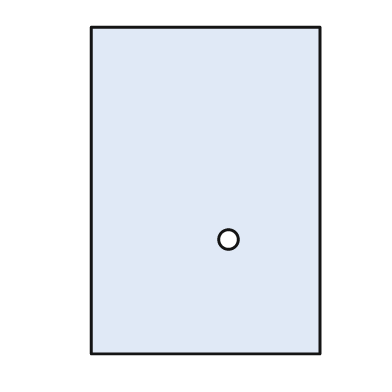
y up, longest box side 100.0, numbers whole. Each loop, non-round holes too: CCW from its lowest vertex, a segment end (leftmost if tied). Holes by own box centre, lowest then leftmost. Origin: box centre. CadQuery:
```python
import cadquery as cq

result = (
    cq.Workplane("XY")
    .moveTo(-35.0, -50.0)
    .lineTo(35.0, -50.0)
    .lineTo(35.0, 50.0)
    .lineTo(-35.0, 50.0)
    .close()
    .moveTo(7.0, -15.0)
    .circle(3.0)
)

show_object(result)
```